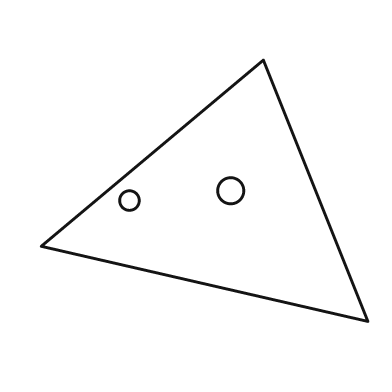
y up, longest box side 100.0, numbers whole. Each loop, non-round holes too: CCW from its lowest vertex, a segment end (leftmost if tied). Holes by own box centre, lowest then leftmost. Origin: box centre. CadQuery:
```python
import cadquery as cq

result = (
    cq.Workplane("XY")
    .moveTo(50.0, -40.0)
    .lineTo(18.0, 40.0)
    .lineTo(-50.0, -17.0)
    .close()
    .moveTo(-23.0, -3.0)
    .circle(3.0)
    .moveTo(8.0, 0.0)
    .circle(4.0)
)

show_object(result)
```